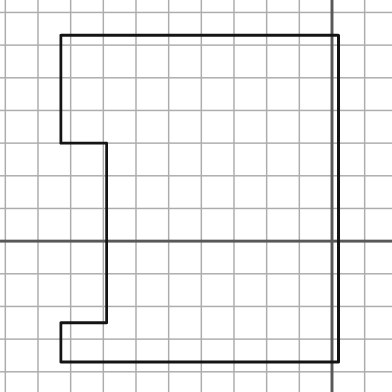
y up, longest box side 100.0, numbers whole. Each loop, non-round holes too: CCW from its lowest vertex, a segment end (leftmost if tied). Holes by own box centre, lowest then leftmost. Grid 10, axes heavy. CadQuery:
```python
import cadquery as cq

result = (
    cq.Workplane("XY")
    .moveTo(-83.0, -37.0)
    .lineTo(2.0, -37.0)
    .lineTo(2.0, 63.0)
    .lineTo(-83.0, 63.0)
    .lineTo(-83.0, 30.0)
    .lineTo(-69.0, 30.0)
    .lineTo(-69.0, -25.0)
    .lineTo(-83.0, -25.0)
    .close()
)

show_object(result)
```